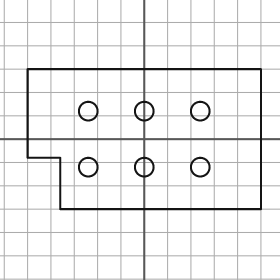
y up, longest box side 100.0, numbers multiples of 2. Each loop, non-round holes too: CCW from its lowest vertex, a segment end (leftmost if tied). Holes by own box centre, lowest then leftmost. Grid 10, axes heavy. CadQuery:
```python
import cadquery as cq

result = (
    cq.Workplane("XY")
    .moveTo(-36.0, -30.0)
    .lineTo(50.0, -30.0)
    .lineTo(50.0, 30.0)
    .lineTo(-50.0, 30.0)
    .lineTo(-50.0, -8.0)
    .lineTo(-36.0, -8.0)
    .close()
    .moveTo(-24.0, -12.0)
    .circle(4.0)
    .moveTo(0.0, -12.0)
    .circle(4.0)
    .moveTo(24.0, -12.0)
    .circle(4.0)
    .moveTo(-24.0, 12.0)
    .circle(4.0)
    .moveTo(0.0, 12.0)
    .circle(4.0)
    .moveTo(24.0, 12.0)
    .circle(4.0)
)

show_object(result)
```